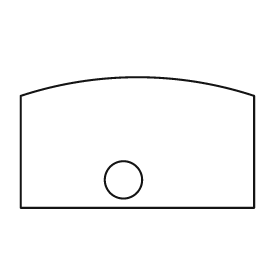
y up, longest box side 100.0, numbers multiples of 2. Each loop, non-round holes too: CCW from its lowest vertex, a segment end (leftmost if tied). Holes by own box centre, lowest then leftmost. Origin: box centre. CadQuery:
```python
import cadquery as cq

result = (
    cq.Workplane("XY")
    .moveTo(-50.0, -28.0)
    .lineTo(50.0, -28.0)
    .lineTo(50.0, 20.0)
    .threePointArc((0.0, 28.0), (-50.0, 20.0))
    .close()
    .moveTo(-6.0, -16.0)
    .circle(8.0)
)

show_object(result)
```